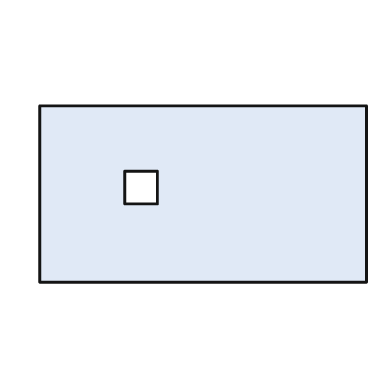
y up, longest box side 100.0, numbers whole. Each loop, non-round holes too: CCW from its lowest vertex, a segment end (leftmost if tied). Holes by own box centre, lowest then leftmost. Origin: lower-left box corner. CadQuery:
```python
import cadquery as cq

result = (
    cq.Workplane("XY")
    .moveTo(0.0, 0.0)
    .lineTo(100.0, 0.0)
    .lineTo(100.0, 54.0)
    .lineTo(0.0, 54.0)
    .close()
    .moveTo(26.0, 24.0)
    .lineTo(36.0, 24.0)
    .lineTo(36.0, 34.0)
    .lineTo(26.0, 34.0)
    .close()
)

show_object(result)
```